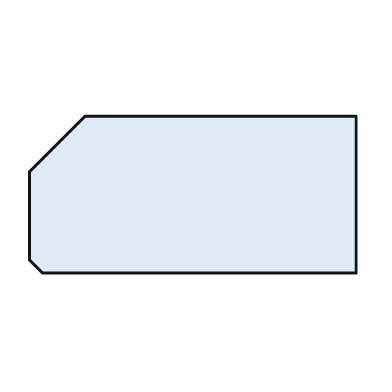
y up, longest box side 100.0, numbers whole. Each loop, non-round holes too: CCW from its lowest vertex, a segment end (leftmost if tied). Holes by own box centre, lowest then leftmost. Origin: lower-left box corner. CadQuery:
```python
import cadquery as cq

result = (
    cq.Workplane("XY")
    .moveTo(4.0, 0.0)
    .lineTo(100.0, 0.0)
    .lineTo(100.0, 48.0)
    .lineTo(17.0, 48.0)
    .lineTo(0.0, 31.0)
    .lineTo(0.0, 4.0)
    .close()
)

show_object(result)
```